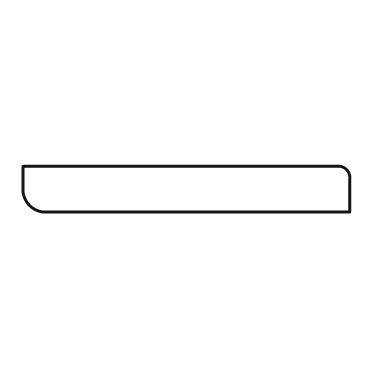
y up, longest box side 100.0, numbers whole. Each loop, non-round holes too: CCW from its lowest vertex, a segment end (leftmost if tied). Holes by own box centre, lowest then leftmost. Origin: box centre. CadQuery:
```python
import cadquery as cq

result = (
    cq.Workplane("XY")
    .moveTo(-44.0, -7.0)
    .lineTo(50.0, -7.0)
    .lineTo(50.0, 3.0)
    .threePointArc((49.0, 6.0), (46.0, 7.0))
    .lineTo(-50.0, 7.0)
    .lineTo(-50.0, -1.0)
    .threePointArc((-48.0, -5.0), (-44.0, -7.0))
    .close()
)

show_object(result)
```